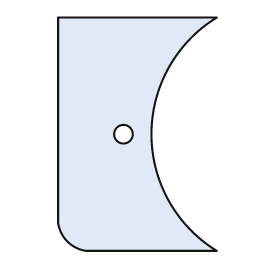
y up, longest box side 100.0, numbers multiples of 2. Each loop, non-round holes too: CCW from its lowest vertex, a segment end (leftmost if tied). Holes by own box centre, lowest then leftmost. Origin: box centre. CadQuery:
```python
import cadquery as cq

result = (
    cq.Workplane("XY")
    .moveTo(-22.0, -50.0)
    .lineTo(34.0, -50.0)
    .threePointArc((6.0, 0.0), (34.0, 50.0))
    .lineTo(-34.0, 50.0)
    .lineTo(-34.0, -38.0)
    .threePointArc((-30.0, -46.0), (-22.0, -50.0))
    .close()
    .moveTo(-6.0, 0.0)
    .circle(4.0)
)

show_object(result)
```